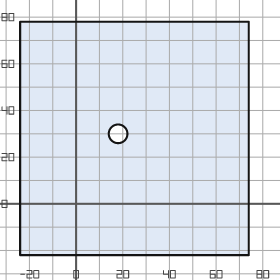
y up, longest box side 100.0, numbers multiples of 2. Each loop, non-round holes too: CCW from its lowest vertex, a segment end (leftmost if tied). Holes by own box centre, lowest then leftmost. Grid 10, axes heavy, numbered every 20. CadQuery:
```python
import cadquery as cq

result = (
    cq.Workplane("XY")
    .moveTo(-24.0, -22.0)
    .lineTo(74.0, -22.0)
    .lineTo(74.0, 78.0)
    .lineTo(-24.0, 78.0)
    .close()
    .moveTo(18.0, 30.0)
    .circle(4.0)
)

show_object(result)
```